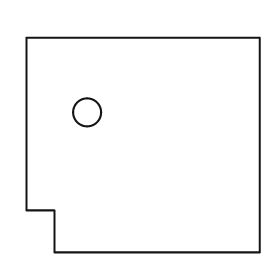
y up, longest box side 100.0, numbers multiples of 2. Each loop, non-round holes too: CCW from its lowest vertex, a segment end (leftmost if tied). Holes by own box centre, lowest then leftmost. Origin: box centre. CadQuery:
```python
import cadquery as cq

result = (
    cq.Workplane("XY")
    .moveTo(-38.0, -46.0)
    .lineTo(50.0, -46.0)
    .lineTo(50.0, 46.0)
    .lineTo(-50.0, 46.0)
    .lineTo(-50.0, -28.0)
    .lineTo(-38.0, -28.0)
    .close()
    .moveTo(-24.0, 14.0)
    .circle(6.0)
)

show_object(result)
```